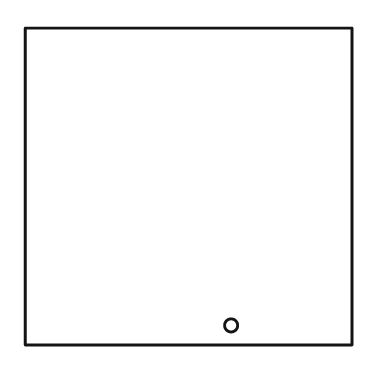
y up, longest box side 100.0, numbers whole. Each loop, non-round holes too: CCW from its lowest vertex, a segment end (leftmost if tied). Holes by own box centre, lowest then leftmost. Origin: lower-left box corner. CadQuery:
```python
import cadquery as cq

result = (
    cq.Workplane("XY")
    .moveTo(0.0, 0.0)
    .lineTo(100.0, 0.0)
    .lineTo(100.0, 97.0)
    .lineTo(0.0, 97.0)
    .close()
    .moveTo(63.0, 6.0)
    .circle(2.0)
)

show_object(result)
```